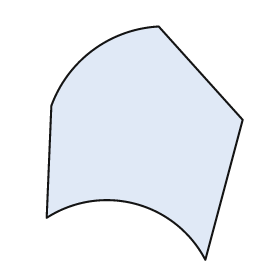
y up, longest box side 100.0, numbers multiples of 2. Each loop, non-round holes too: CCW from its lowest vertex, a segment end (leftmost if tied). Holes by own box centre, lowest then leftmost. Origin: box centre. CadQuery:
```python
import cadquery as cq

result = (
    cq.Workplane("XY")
    .moveTo(26.0, -50.0)
    .lineTo(42.0, 10.0)
    .lineTo(6.0, 50.0)
    .threePointArc((-22.0, 40.0), (-40.0, 16.0))
    .lineTo(-42.0, -32.0)
    .threePointArc((-4.0, -26.0), (26.0, -50.0))
    .close()
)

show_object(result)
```